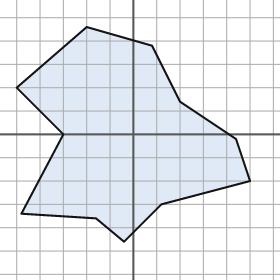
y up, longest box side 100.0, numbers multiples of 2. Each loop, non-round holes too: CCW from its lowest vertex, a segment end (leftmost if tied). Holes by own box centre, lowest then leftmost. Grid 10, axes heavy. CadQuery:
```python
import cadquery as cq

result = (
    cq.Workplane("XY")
    .moveTo(-4.0, -46.0)
    .lineTo(12.0, -30.0)
    .lineTo(50.0, -20.0)
    .lineTo(44.0, -2.0)
    .lineTo(20.0, 14.0)
    .lineTo(8.0, 38.0)
    .lineTo(-20.0, 46.0)
    .lineTo(-50.0, 20.0)
    .lineTo(-30.0, 0.0)
    .lineTo(-48.0, -34.0)
    .lineTo(-16.0, -36.0)
    .close()
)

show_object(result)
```